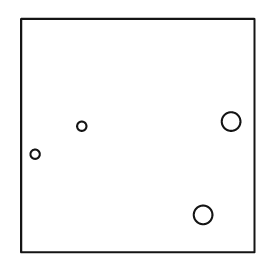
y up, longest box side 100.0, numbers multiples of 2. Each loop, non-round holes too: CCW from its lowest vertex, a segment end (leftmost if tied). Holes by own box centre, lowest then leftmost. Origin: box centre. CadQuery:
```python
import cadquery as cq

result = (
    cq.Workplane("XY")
    .moveTo(-50.0, -50.0)
    .lineTo(50.0, -50.0)
    .lineTo(50.0, 50.0)
    .lineTo(-50.0, 50.0)
    .close()
    .moveTo(28.0, -34.0)
    .circle(4.0)
    .moveTo(-44.0, -8.0)
    .circle(2.0)
    .moveTo(-24.0, 4.0)
    .circle(2.0)
    .moveTo(40.0, 6.0)
    .circle(4.0)
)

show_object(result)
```